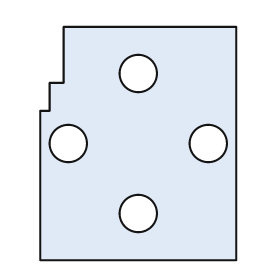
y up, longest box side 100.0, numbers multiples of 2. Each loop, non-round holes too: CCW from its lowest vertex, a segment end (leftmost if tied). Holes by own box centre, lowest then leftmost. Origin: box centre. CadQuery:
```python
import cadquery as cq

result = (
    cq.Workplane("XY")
    .moveTo(-42.0, -50.0)
    .lineTo(42.0, -50.0)
    .lineTo(42.0, 50.0)
    .lineTo(-32.0, 50.0)
    .lineTo(-32.0, 26.0)
    .lineTo(-38.0, 26.0)
    .lineTo(-38.0, 14.0)
    .lineTo(-42.0, 14.0)
    .close()
    .moveTo(0.0, -30.0)
    .circle(8.0)
    .moveTo(-30.0, 0.0)
    .circle(8.0)
    .moveTo(30.0, 0.0)
    .circle(8.0)
    .moveTo(0.0, 30.0)
    .circle(8.0)
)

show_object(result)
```